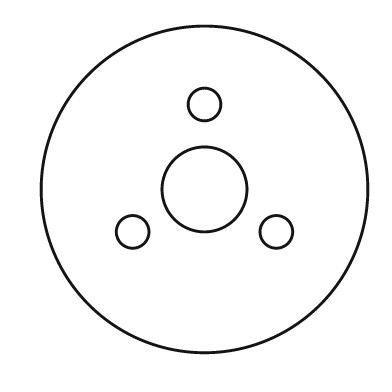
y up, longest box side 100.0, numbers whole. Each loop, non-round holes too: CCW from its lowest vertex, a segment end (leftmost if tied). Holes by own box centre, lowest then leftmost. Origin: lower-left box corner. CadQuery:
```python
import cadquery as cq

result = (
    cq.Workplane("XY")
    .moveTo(50.0, 50.0)
    .circle(50.0)
    .moveTo(28.0, 37.0)
    .circle(5.0)
    .moveTo(72.0, 37.0)
    .circle(5.0)
    .moveTo(50.0, 50.0)
    .circle(13.0)
    .moveTo(50.0, 76.0)
    .circle(5.0)
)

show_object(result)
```